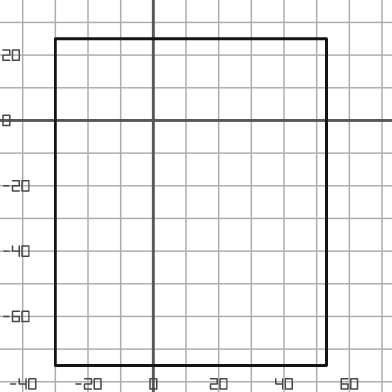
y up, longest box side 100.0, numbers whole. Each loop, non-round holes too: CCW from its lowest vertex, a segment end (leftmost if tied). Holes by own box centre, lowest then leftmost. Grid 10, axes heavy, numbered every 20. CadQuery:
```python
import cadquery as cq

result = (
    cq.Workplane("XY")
    .moveTo(-30.0, -75.0)
    .lineTo(53.0, -75.0)
    .lineTo(53.0, 25.0)
    .lineTo(-30.0, 25.0)
    .close()
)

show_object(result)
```